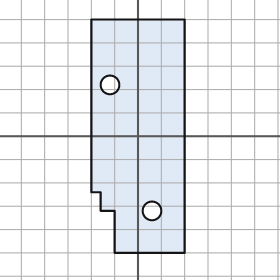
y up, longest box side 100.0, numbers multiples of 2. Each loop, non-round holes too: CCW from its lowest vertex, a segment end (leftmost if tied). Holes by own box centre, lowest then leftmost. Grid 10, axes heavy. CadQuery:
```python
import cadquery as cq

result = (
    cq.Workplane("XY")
    .moveTo(-10.0, -50.0)
    .lineTo(20.0, -50.0)
    .lineTo(20.0, 50.0)
    .lineTo(-20.0, 50.0)
    .lineTo(-20.0, -24.0)
    .lineTo(-16.0, -24.0)
    .lineTo(-16.0, -32.0)
    .lineTo(-10.0, -32.0)
    .close()
    .moveTo(6.0, -32.0)
    .circle(4.0)
    .moveTo(-12.0, 22.0)
    .circle(4.0)
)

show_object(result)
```